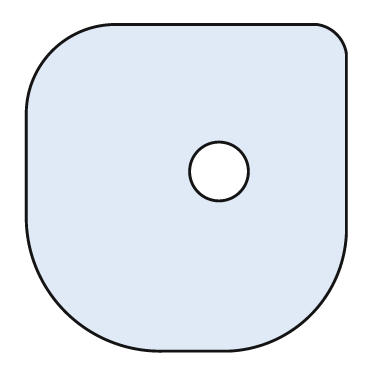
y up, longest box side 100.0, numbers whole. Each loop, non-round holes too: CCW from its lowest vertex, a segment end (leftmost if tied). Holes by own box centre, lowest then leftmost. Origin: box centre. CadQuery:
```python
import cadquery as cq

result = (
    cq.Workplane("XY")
    .moveTo(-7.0, -50.0)
    .lineTo(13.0, -50.0)
    .threePointArc((38.0, -39.0), (49.0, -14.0))
    .lineTo(49.0, 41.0)
    .threePointArc((46.0, 47.0), (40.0, 50.0))
    .lineTo(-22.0, 50.0)
    .threePointArc((-41.0, 42.0), (-49.0, 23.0))
    .lineTo(-49.0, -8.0)
    .threePointArc((-37.0, -38.0), (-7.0, -50.0))
    .close()
    .moveTo(10.0, 5.0)
    .circle(9.0)
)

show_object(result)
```